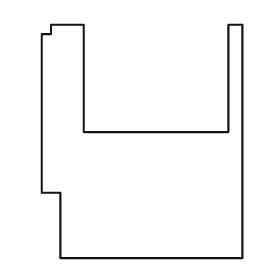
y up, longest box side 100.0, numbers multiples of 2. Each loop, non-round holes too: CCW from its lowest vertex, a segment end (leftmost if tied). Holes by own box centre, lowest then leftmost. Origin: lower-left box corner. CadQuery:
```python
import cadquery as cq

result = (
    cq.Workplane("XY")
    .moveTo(8.0, 0.0)
    .lineTo(86.0, 0.0)
    .lineTo(86.0, 100.0)
    .lineTo(80.0, 100.0)
    .lineTo(80.0, 54.0)
    .lineTo(18.0, 54.0)
    .lineTo(18.0, 100.0)
    .lineTo(4.0, 100.0)
    .lineTo(4.0, 96.0)
    .lineTo(0.0, 96.0)
    .lineTo(0.0, 28.0)
    .lineTo(8.0, 28.0)
    .close()
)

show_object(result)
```